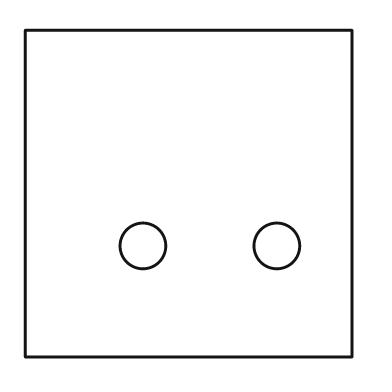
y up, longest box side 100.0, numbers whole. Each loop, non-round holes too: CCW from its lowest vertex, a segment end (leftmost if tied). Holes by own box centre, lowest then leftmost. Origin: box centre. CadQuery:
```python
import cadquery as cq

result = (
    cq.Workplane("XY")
    .moveTo(-50.0, -50.0)
    .lineTo(50.0, -50.0)
    .lineTo(50.0, 50.0)
    .lineTo(-50.0, 50.0)
    .close()
    .moveTo(-14.0, -16.0)
    .circle(7.0)
    .moveTo(27.0, -16.0)
    .circle(7.0)
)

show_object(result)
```